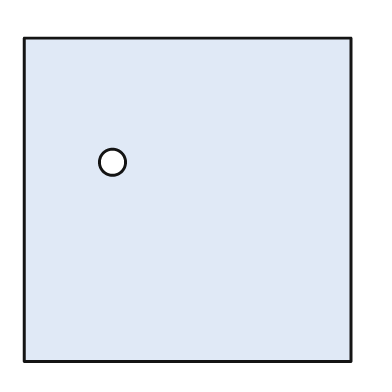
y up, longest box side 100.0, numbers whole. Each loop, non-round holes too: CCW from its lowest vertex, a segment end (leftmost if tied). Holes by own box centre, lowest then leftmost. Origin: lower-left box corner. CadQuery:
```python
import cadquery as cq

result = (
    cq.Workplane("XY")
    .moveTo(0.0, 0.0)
    .lineTo(100.0, 0.0)
    .lineTo(100.0, 99.0)
    .lineTo(0.0, 99.0)
    .close()
    .moveTo(27.0, 61.0)
    .circle(4.0)
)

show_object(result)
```